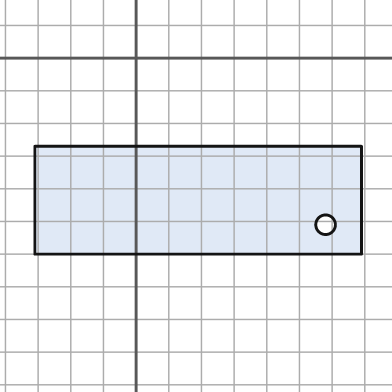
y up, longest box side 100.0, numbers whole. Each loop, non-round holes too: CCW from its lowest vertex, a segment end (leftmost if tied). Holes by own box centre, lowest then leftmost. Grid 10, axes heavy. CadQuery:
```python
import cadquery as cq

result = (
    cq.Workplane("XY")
    .moveTo(-31.0, -60.0)
    .lineTo(69.0, -60.0)
    .lineTo(69.0, -27.0)
    .lineTo(-31.0, -27.0)
    .close()
    .moveTo(58.0, -51.0)
    .circle(3.0)
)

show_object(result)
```